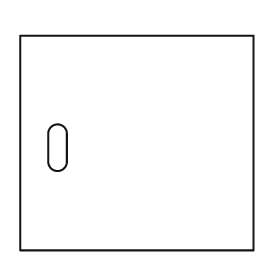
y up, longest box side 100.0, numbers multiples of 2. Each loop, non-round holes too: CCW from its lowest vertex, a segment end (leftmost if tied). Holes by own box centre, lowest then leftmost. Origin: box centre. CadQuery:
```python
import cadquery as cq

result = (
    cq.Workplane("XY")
    .moveTo(-50.0, -46.0)
    .lineTo(50.0, -46.0)
    .lineTo(50.0, 46.0)
    .lineTo(-50.0, 46.0)
    .close()
    .moveTo(-38.0, -8.0)
    .threePointArc((-34.0, -12.0), (-30.0, -8.0))
    .lineTo(-30.0, 4.0)
    .threePointArc((-34.0, 8.0), (-38.0, 4.0))
    .close()
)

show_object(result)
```